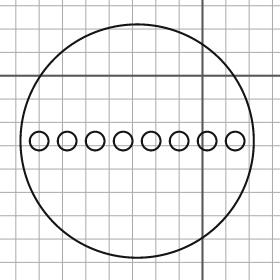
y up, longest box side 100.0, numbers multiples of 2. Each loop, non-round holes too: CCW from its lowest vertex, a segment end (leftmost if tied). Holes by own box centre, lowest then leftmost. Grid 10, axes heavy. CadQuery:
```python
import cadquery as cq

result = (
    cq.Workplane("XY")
    .moveTo(-28.0, -28.0)
    .circle(50.0)
    .moveTo(-70.0, -28.0)
    .circle(4.0)
    .moveTo(-58.0, -28.0)
    .circle(4.0)
    .moveTo(-46.0, -28.0)
    .circle(4.0)
    .moveTo(-34.0, -28.0)
    .circle(4.0)
    .moveTo(-22.0, -28.0)
    .circle(4.0)
    .moveTo(-10.0, -28.0)
    .circle(4.0)
    .moveTo(2.0, -28.0)
    .circle(4.0)
    .moveTo(14.0, -28.0)
    .circle(4.0)
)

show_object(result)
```